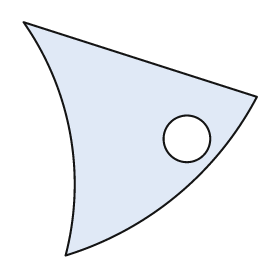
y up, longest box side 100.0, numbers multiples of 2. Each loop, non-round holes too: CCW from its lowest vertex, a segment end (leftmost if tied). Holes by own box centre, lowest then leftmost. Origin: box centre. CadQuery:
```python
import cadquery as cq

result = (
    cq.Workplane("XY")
    .moveTo(-32.0, -50.0)
    .threePointArc((16.0, -24.0), (50.0, 18.0))
    .lineTo(-50.0, 50.0)
    .threePointArc((-30.0, 2.0), (-32.0, -50.0))
    .close()
    .moveTo(20.0, 0.0)
    .circle(10.0)
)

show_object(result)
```